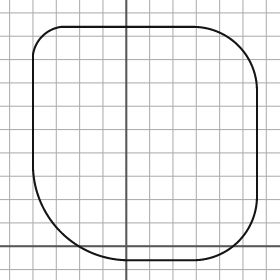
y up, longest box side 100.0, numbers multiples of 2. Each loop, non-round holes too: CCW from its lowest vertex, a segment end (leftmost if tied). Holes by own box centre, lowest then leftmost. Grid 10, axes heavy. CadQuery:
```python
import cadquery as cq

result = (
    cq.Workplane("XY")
    .moveTo(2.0, -6.0)
    .lineTo(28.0, -6.0)
    .threePointArc((48.0, 2.0), (56.0, 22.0))
    .lineTo(56.0, 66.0)
    .threePointArc((48.0, 86.0), (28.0, 94.0))
    .lineTo(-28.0, 94.0)
    .threePointArc((-36.0, 90.0), (-40.0, 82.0))
    .lineTo(-40.0, 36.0)
    .threePointArc((-28.0, 6.0), (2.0, -6.0))
    .close()
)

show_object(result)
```